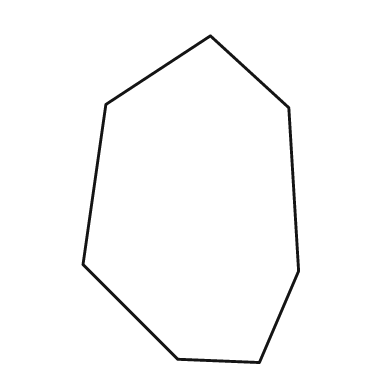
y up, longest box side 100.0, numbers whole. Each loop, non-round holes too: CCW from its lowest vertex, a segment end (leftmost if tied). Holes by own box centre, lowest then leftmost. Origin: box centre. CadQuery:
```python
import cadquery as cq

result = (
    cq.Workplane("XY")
    .moveTo(21.0, -50.0)
    .lineTo(33.0, -22.0)
    .lineTo(30.0, 28.0)
    .lineTo(6.0, 50.0)
    .lineTo(-26.0, 29.0)
    .lineTo(-33.0, -20.0)
    .lineTo(-4.0, -49.0)
    .close()
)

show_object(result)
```